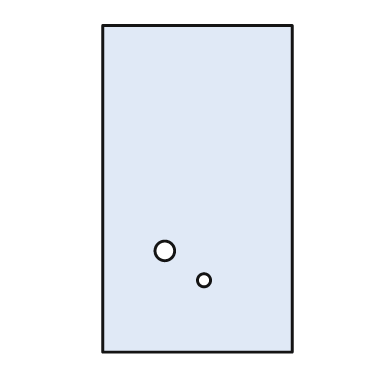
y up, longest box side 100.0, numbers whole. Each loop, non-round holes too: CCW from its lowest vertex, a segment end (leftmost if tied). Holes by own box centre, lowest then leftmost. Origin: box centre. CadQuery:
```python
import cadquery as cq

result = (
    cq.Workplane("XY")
    .moveTo(-29.0, -50.0)
    .lineTo(29.0, -50.0)
    .lineTo(29.0, 50.0)
    .lineTo(-29.0, 50.0)
    .close()
    .moveTo(2.0, -28.0)
    .circle(2.0)
    .moveTo(-10.0, -19.0)
    .circle(3.0)
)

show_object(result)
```